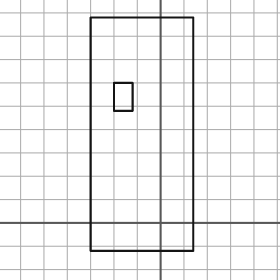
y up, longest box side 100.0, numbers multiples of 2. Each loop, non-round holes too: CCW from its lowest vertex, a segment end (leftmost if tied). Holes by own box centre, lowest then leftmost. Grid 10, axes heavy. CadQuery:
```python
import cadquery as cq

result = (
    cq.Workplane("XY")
    .moveTo(-30.0, -12.0)
    .lineTo(14.0, -12.0)
    .lineTo(14.0, 88.0)
    .lineTo(-30.0, 88.0)
    .close()
    .moveTo(-20.0, 48.0)
    .lineTo(-12.0, 48.0)
    .lineTo(-12.0, 60.0)
    .lineTo(-20.0, 60.0)
    .close()
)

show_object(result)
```